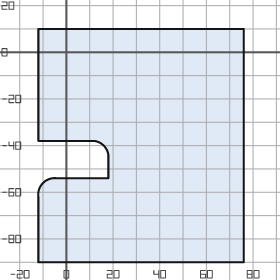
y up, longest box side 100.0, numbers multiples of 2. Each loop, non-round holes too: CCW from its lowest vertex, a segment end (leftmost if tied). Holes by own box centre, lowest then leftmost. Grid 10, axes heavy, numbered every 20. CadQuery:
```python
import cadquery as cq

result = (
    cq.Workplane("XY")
    .moveTo(-12.0, -90.0)
    .lineTo(76.0, -90.0)
    .lineTo(76.0, 10.0)
    .lineTo(-12.0, 10.0)
    .lineTo(-12.0, -38.0)
    .lineTo(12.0, -38.0)
    .threePointArc((16.0, -40.0), (18.0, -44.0))
    .lineTo(18.0, -54.0)
    .lineTo(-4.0, -54.0)
    .threePointArc((-10.0, -56.0), (-12.0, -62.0))
    .close()
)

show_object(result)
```